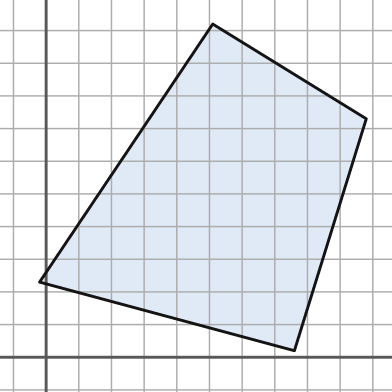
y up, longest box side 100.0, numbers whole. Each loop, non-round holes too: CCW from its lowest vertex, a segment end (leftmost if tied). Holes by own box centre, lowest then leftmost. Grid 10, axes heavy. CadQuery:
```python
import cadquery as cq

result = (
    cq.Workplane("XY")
    .moveTo(76.0, 2.0)
    .lineTo(98.0, 73.0)
    .lineTo(51.0, 102.0)
    .lineTo(-2.0, 23.0)
    .close()
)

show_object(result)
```